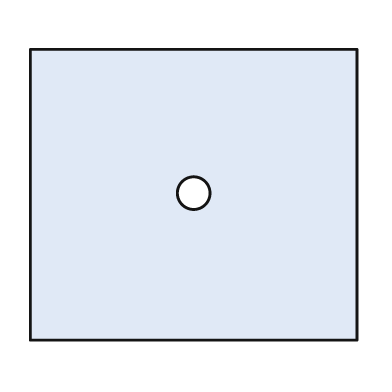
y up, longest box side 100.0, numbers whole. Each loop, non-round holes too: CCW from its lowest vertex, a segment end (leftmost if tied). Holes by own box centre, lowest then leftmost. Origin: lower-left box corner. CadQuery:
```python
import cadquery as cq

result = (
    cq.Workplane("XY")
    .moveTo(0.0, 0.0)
    .lineTo(100.0, 0.0)
    .lineTo(100.0, 89.0)
    .lineTo(0.0, 89.0)
    .close()
    .moveTo(50.0, 45.0)
    .circle(5.0)
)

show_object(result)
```